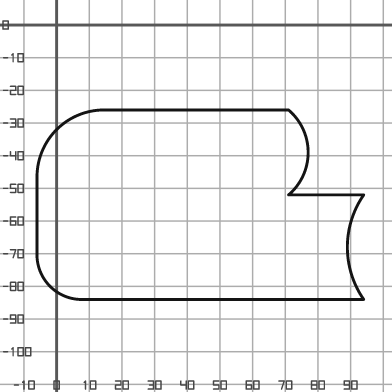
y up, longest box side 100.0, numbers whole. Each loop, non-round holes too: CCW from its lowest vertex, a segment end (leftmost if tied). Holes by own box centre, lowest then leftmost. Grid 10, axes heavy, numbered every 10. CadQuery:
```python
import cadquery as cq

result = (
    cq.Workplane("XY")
    .moveTo(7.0, -84.0)
    .lineTo(94.0, -84.0)
    .threePointArc((89.0, -68.0), (94.0, -52.0))
    .lineTo(71.0, -52.0)
    .threePointArc((77.0, -39.0), (71.0, -26.0))
    .lineTo(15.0, -26.0)
    .threePointArc((0.0, -32.0), (-6.0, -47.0))
    .lineTo(-6.0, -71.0)
    .threePointArc((-2.0, -80.0), (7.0, -84.0))
    .close()
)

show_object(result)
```